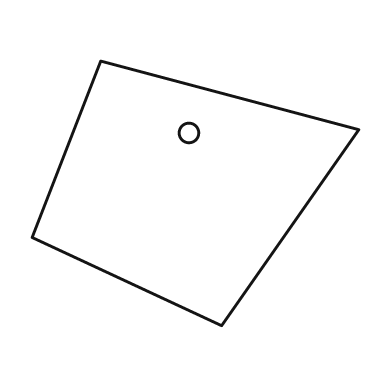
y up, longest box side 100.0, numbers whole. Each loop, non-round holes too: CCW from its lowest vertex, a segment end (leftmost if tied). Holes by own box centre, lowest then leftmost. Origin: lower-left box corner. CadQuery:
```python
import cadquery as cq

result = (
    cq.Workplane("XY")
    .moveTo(58.0, 0.0)
    .lineTo(100.0, 60.0)
    .lineTo(21.0, 81.0)
    .lineTo(0.0, 27.0)
    .close()
    .moveTo(48.0, 59.0)
    .circle(3.0)
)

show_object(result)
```